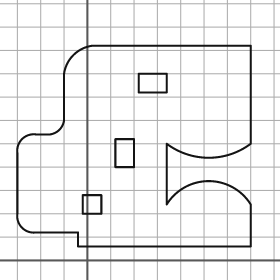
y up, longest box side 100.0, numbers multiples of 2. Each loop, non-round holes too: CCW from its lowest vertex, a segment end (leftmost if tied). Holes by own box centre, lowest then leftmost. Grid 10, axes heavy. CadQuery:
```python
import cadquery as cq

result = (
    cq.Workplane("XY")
    .moveTo(-4.0, 6.0)
    .lineTo(70.0, 6.0)
    .lineTo(70.0, 24.0)
    .threePointArc((52.0, 34.0), (34.0, 24.0))
    .lineTo(34.0, 50.0)
    .threePointArc((52.0, 44.0), (70.0, 50.0))
    .lineTo(70.0, 92.0)
    .lineTo(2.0, 92.0)
    .threePointArc((-6.0, 88.0), (-10.0, 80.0))
    .lineTo(-10.0, 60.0)
    .threePointArc((-12.0, 56.0), (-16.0, 54.0))
    .lineTo(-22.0, 54.0)
    .threePointArc((-28.0, 52.0), (-30.0, 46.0))
    .lineTo(-30.0, 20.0)
    .threePointArc((-28.0, 14.0), (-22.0, 12.0))
    .lineTo(-4.0, 12.0)
    .close()
    .moveTo(-2.0, 20.0)
    .lineTo(6.0, 20.0)
    .lineTo(6.0, 28.0)
    .lineTo(-2.0, 28.0)
    .close()
    .moveTo(12.0, 40.0)
    .lineTo(20.0, 40.0)
    .lineTo(20.0, 52.0)
    .lineTo(12.0, 52.0)
    .close()
    .moveTo(22.0, 72.0)
    .lineTo(34.0, 72.0)
    .lineTo(34.0, 80.0)
    .lineTo(22.0, 80.0)
    .close()
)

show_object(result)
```